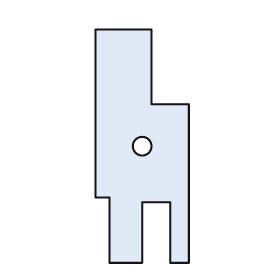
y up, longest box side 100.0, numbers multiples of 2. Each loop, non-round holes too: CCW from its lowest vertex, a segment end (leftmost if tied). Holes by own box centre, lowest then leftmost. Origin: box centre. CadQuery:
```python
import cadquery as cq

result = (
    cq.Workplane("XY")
    .moveTo(-14.0, -50.0)
    .lineTo(0.0, -50.0)
    .lineTo(0.0, -24.0)
    .lineTo(12.0, -24.0)
    .lineTo(12.0, -50.0)
    .lineTo(20.0, -50.0)
    .lineTo(20.0, 18.0)
    .lineTo(4.0, 18.0)
    .lineTo(4.0, 50.0)
    .lineTo(-20.0, 50.0)
    .lineTo(-20.0, -22.0)
    .lineTo(-14.0, -22.0)
    .close()
    .moveTo(0.0, 0.0)
    .circle(4.0)
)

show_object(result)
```